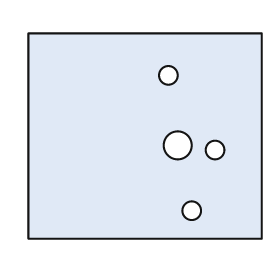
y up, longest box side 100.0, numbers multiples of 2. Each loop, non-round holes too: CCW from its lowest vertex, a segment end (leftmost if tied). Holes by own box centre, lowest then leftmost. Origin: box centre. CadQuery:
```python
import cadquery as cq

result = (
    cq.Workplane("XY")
    .moveTo(-50.0, -44.0)
    .lineTo(50.0, -44.0)
    .lineTo(50.0, 44.0)
    .lineTo(-50.0, 44.0)
    .close()
    .moveTo(20.0, -32.0)
    .circle(4.0)
    .moveTo(30.0, -6.0)
    .circle(4.0)
    .moveTo(14.0, -4.0)
    .circle(6.0)
    .moveTo(10.0, 26.0)
    .circle(4.0)
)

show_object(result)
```